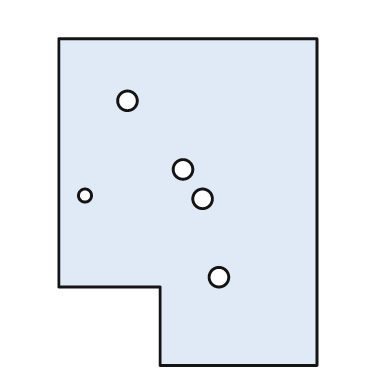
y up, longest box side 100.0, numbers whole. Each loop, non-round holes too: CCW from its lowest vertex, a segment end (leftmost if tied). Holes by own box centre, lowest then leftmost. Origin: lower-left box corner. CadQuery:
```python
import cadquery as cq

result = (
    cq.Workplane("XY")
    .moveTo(31.0, 0.0)
    .lineTo(79.0, 0.0)
    .lineTo(79.0, 100.0)
    .lineTo(0.0, 100.0)
    .lineTo(0.0, 24.0)
    .lineTo(31.0, 24.0)
    .close()
    .moveTo(49.0, 27.0)
    .circle(3.0)
    .moveTo(44.0, 51.0)
    .circle(3.0)
    .moveTo(8.0, 52.0)
    .circle(2.0)
    .moveTo(38.0, 60.0)
    .circle(3.0)
    .moveTo(21.0, 81.0)
    .circle(3.0)
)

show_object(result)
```